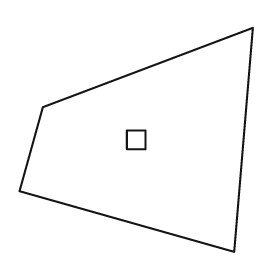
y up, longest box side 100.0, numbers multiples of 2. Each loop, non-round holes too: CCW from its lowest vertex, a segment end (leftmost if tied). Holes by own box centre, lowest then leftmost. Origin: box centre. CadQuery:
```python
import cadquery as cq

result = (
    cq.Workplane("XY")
    .moveTo(42.0, -48.0)
    .lineTo(50.0, 48.0)
    .lineTo(-40.0, 14.0)
    .lineTo(-50.0, -22.0)
    .close()
    .moveTo(-4.0, -4.0)
    .lineTo(4.0, -4.0)
    .lineTo(4.0, 4.0)
    .lineTo(-4.0, 4.0)
    .close()
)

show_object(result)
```